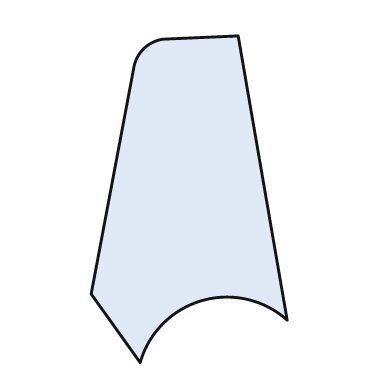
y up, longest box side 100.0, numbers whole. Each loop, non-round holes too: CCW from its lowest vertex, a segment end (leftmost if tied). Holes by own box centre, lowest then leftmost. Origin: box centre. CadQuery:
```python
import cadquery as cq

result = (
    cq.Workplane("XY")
    .moveTo(-15.0, -50.0)
    .threePointArc((4.0, -31.0), (30.0, -37.0))
    .lineTo(15.0, 50.0)
    .lineTo(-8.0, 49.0)
    .threePointArc((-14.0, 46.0), (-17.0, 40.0))
    .lineTo(-30.0, -29.0)
    .close()
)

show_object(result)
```